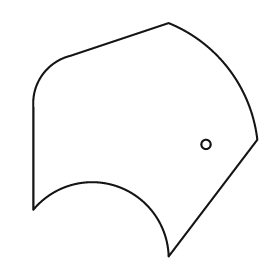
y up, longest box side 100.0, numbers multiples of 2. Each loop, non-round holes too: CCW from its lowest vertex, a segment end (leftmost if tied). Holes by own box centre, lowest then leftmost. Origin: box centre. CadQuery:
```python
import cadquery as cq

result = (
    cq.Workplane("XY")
    .moveTo(10.0, -50.0)
    .lineTo(48.0, 0.0)
    .threePointArc((36.0, 30.0), (10.0, 50.0))
    .lineTo(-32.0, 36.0)
    .threePointArc((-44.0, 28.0), (-48.0, 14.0))
    .lineTo(-48.0, -30.0)
    .threePointArc((-12.0, -20.0), (10.0, -50.0))
    .close()
    .moveTo(26.0, -2.0)
    .circle(2.0)
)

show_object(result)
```